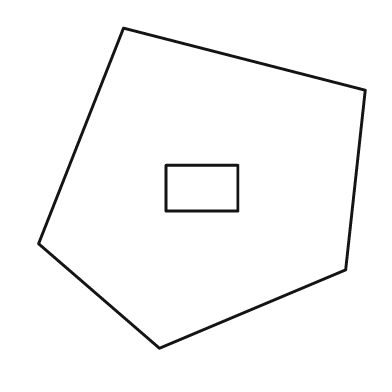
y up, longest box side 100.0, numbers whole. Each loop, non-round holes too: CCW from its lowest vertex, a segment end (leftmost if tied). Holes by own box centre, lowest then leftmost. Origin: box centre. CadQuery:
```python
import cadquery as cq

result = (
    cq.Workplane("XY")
    .moveTo(-13.0, -49.0)
    .lineTo(44.0, -25.0)
    .lineTo(50.0, 30.0)
    .lineTo(-24.0, 49.0)
    .lineTo(-50.0, -17.0)
    .close()
    .moveTo(-11.0, -7.0)
    .lineTo(11.0, -7.0)
    .lineTo(11.0, 7.0)
    .lineTo(-11.0, 7.0)
    .close()
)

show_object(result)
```